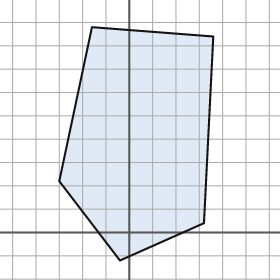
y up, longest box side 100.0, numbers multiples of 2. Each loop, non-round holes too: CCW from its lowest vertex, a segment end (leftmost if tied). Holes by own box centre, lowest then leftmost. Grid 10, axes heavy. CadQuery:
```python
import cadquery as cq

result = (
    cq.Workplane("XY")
    .moveTo(-4.0, -12.0)
    .lineTo(32.0, 4.0)
    .lineTo(36.0, 84.0)
    .lineTo(-16.0, 88.0)
    .lineTo(-30.0, 22.0)
    .close()
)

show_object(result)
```